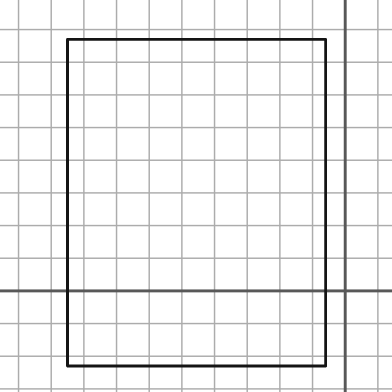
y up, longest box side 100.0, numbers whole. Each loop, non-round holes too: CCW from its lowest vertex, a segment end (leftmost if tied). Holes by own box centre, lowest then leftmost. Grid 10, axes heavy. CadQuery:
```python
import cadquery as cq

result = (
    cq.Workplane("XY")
    .moveTo(-85.0, -23.0)
    .lineTo(-6.0, -23.0)
    .lineTo(-6.0, 77.0)
    .lineTo(-85.0, 77.0)
    .close()
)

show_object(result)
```